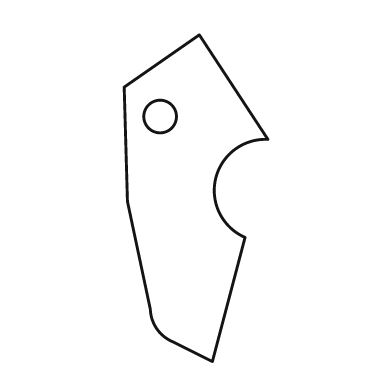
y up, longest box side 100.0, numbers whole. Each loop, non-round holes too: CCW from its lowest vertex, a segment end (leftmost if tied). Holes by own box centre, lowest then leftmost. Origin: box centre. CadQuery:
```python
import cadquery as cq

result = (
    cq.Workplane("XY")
    .moveTo(5.0, -50.0)
    .lineTo(15.0, -12.0)
    .threePointArc((6.0, 6.0), (22.0, 18.0))
    .lineTo(1.0, 50.0)
    .lineTo(-22.0, 34.0)
    .lineTo(-21.0, -1.0)
    .lineTo(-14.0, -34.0)
    .threePointArc((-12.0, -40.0), (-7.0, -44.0))
    .close()
    .moveTo(-11.0, 25.0)
    .circle(5.0)
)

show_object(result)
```